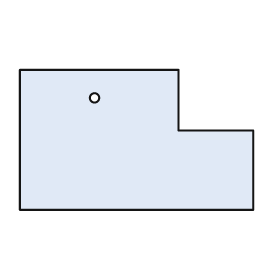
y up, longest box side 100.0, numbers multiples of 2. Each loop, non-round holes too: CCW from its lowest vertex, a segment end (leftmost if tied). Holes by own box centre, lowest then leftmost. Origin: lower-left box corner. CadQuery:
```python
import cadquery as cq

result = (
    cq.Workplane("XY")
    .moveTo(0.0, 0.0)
    .lineTo(100.0, 0.0)
    .lineTo(100.0, 34.0)
    .lineTo(68.0, 34.0)
    .lineTo(68.0, 60.0)
    .lineTo(0.0, 60.0)
    .close()
    .moveTo(32.0, 48.0)
    .circle(2.0)
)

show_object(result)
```